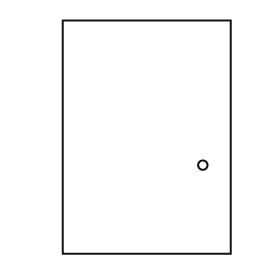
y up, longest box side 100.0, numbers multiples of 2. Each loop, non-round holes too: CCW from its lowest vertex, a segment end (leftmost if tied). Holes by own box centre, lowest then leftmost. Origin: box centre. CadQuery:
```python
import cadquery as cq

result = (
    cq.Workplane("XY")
    .moveTo(-36.0, -50.0)
    .lineTo(36.0, -50.0)
    .lineTo(36.0, 50.0)
    .lineTo(-36.0, 50.0)
    .close()
    .moveTo(24.0, -12.0)
    .circle(2.0)
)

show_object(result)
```